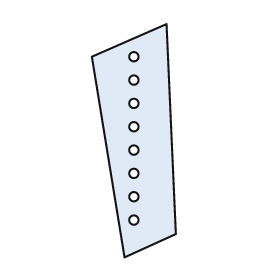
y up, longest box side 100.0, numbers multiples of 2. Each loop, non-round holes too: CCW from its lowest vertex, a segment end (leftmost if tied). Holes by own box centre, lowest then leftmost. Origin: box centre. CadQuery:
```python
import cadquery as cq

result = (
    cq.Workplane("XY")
    .moveTo(-4.0, -50.0)
    .lineTo(18.0, -40.0)
    .lineTo(14.0, 50.0)
    .lineTo(-18.0, 36.0)
    .close()
    .moveTo(0.0, -34.0)
    .circle(2.0)
    .moveTo(0.0, -24.0)
    .circle(2.0)
    .moveTo(0.0, -14.0)
    .circle(2.0)
    .moveTo(0.0, -4.0)
    .circle(2.0)
    .moveTo(0.0, 6.0)
    .circle(2.0)
    .moveTo(0.0, 16.0)
    .circle(2.0)
    .moveTo(0.0, 26.0)
    .circle(2.0)
    .moveTo(0.0, 36.0)
    .circle(2.0)
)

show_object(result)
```